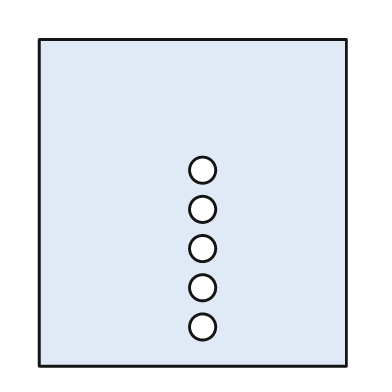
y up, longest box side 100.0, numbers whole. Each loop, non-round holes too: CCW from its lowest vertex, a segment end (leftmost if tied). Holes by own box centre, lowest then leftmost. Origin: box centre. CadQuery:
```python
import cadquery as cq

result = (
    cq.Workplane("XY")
    .moveTo(-47.0, -50.0)
    .lineTo(47.0, -50.0)
    .lineTo(47.0, 50.0)
    .lineTo(-47.0, 50.0)
    .close()
    .moveTo(3.0, -38.0)
    .circle(4.0)
    .moveTo(3.0, -26.0)
    .circle(4.0)
    .moveTo(3.0, -14.0)
    .circle(4.0)
    .moveTo(3.0, -2.0)
    .circle(4.0)
    .moveTo(3.0, 10.0)
    .circle(4.0)
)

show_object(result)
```